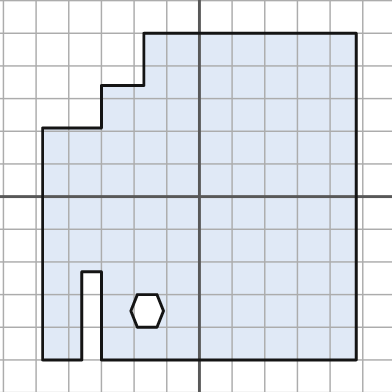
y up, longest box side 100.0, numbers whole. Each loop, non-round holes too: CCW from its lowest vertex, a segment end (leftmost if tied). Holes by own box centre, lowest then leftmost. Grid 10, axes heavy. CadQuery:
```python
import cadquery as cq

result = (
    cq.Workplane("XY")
    .moveTo(-48.0, -50.0)
    .lineTo(-36.0, -50.0)
    .lineTo(-36.0, -23.0)
    .lineTo(-30.0, -23.0)
    .lineTo(-30.0, -50.0)
    .lineTo(48.0, -50.0)
    .lineTo(48.0, 50.0)
    .lineTo(-17.0, 50.0)
    .lineTo(-17.0, 34.0)
    .lineTo(-30.0, 34.0)
    .lineTo(-30.0, 21.0)
    .lineTo(-48.0, 21.0)
    .close()
    .moveTo(-19.0, -40.0)
    .lineTo(-13.0, -40.0)
    .lineTo(-11.0, -35.0)
    .lineTo(-13.0, -30.0)
    .lineTo(-19.0, -30.0)
    .lineTo(-21.0, -35.0)
    .close()
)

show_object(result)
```